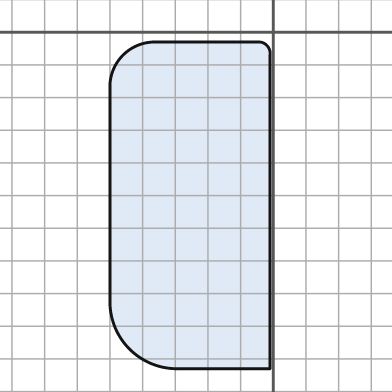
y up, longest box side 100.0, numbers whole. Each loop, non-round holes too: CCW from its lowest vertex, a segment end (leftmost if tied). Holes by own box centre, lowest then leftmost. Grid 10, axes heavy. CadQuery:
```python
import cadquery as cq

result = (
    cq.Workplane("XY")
    .moveTo(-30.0, -103.0)
    .lineTo(-1.0, -103.0)
    .lineTo(-1.0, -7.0)
    .threePointArc((-2.0, -4.0), (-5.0, -3.0))
    .lineTo(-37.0, -3.0)
    .threePointArc((-46.0, -7.0), (-50.0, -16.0))
    .lineTo(-50.0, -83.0)
    .threePointArc((-44.0, -97.0), (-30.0, -103.0))
    .close()
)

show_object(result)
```